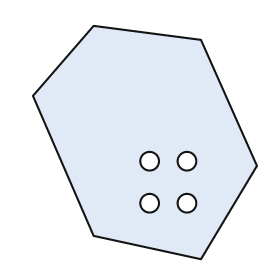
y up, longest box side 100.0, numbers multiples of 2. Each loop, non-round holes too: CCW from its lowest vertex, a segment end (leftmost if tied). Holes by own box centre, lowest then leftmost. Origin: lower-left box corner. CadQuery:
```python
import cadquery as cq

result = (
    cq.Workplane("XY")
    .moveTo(72.0, 0.0)
    .lineTo(96.0, 40.0)
    .lineTo(72.0, 94.0)
    .lineTo(26.0, 100.0)
    .lineTo(0.0, 70.0)
    .lineTo(26.0, 10.0)
    .close()
    .moveTo(50.0, 24.0)
    .circle(4.0)
    .moveTo(66.0, 24.0)
    .circle(4.0)
    .moveTo(50.0, 42.0)
    .circle(4.0)
    .moveTo(66.0, 42.0)
    .circle(4.0)
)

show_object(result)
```